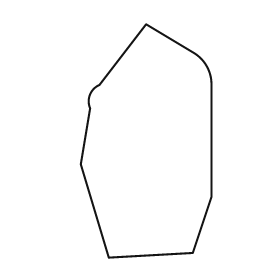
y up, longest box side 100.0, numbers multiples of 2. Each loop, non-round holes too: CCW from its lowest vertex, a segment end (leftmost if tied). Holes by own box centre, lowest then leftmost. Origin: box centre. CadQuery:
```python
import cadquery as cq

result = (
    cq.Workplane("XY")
    .moveTo(-16.0, -50.0)
    .lineTo(20.0, -48.0)
    .lineTo(28.0, -24.0)
    .lineTo(28.0, 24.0)
    .threePointArc((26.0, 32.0), (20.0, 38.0))
    .lineTo(0.0, 50.0)
    .lineTo(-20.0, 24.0)
    .threePointArc((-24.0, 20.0), (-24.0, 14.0))
    .lineTo(-28.0, -10.0)
    .close()
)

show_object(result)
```